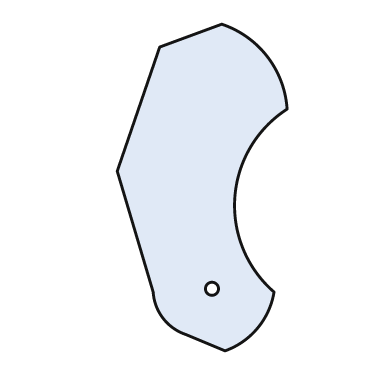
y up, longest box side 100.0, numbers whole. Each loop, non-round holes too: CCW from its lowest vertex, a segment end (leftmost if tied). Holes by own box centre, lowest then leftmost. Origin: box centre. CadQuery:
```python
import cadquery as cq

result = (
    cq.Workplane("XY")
    .moveTo(7.0, -50.0)
    .threePointArc((17.0, -43.0), (22.0, -32.0))
    .threePointArc((10.0, -3.0), (26.0, 24.0))
    .threePointArc((20.0, 40.0), (6.0, 50.0))
    .lineTo(-13.0, 43.0)
    .lineTo(-26.0, 5.0)
    .lineTo(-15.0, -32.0)
    .threePointArc((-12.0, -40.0), (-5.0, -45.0))
    .close()
    .moveTo(3.0, -31.0)
    .circle(2.0)
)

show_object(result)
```